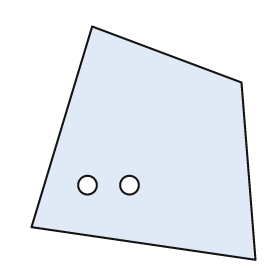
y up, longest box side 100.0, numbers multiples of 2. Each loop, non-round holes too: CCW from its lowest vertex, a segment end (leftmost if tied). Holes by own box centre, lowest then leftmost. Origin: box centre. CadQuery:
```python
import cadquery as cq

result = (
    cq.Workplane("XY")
    .moveTo(48.0, -50.0)
    .lineTo(42.0, 26.0)
    .lineTo(-22.0, 50.0)
    .lineTo(-48.0, -36.0)
    .close()
    .moveTo(-24.0, -18.0)
    .circle(4.0)
    .moveTo(-6.0, -18.0)
    .circle(4.0)
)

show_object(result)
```